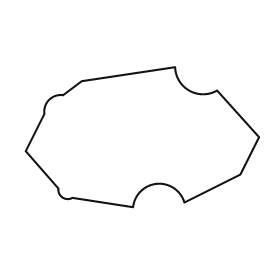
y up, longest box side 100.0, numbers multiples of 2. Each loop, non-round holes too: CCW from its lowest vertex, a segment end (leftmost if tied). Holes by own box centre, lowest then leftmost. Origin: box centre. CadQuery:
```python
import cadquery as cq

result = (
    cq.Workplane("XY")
    .moveTo(-4.0, -30.0)
    .threePointArc((6.0, -20.0), (18.0, -28.0))
    .lineTo(42.0, -16.0)
    .lineTo(50.0, 0.0)
    .lineTo(32.0, 20.0)
    .threePointArc((20.0, 20.0), (14.0, 30.0))
    .lineTo(-26.0, 24.0)
    .lineTo(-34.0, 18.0)
    .threePointArc((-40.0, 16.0), (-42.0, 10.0))
    .lineTo(-50.0, -6.0)
    .lineTo(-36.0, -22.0)
    .threePointArc((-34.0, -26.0), (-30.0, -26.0))
    .close()
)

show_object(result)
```